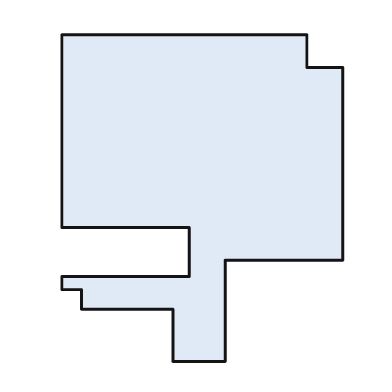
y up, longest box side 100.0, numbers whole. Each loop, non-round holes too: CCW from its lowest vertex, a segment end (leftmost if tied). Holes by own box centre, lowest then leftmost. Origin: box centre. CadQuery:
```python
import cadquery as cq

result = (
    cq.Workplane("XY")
    .moveTo(-9.0, -50.0)
    .lineTo(7.0, -50.0)
    .lineTo(7.0, -19.0)
    .lineTo(43.0, -19.0)
    .lineTo(43.0, 40.0)
    .lineTo(32.0, 40.0)
    .lineTo(32.0, 50.0)
    .lineTo(-43.0, 50.0)
    .lineTo(-43.0, -9.0)
    .lineTo(-4.0, -9.0)
    .lineTo(-4.0, -24.0)
    .lineTo(-43.0, -24.0)
    .lineTo(-43.0, -28.0)
    .lineTo(-37.0, -28.0)
    .lineTo(-37.0, -34.0)
    .lineTo(-9.0, -34.0)
    .close()
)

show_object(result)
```